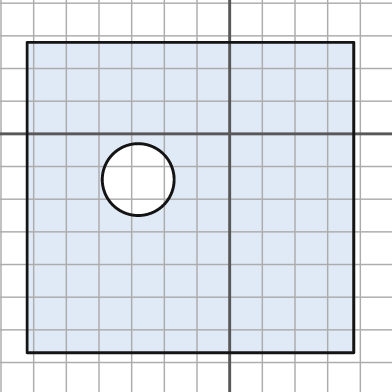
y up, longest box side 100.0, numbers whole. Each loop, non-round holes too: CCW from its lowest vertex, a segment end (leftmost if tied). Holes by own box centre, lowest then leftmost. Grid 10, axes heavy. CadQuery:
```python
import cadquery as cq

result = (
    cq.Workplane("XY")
    .moveTo(-62.0, -67.0)
    .lineTo(38.0, -67.0)
    .lineTo(38.0, 28.0)
    .lineTo(-62.0, 28.0)
    .close()
    .moveTo(-28.0, -14.0)
    .circle(11.0)
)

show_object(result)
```